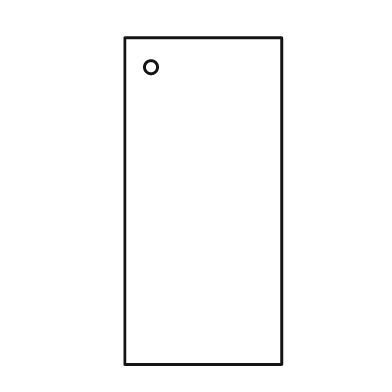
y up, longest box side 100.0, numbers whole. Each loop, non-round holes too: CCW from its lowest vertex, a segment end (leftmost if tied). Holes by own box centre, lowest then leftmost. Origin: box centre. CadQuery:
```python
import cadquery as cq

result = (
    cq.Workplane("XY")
    .moveTo(-24.0, -50.0)
    .lineTo(24.0, -50.0)
    .lineTo(24.0, 50.0)
    .lineTo(-24.0, 50.0)
    .close()
    .moveTo(-16.0, 41.0)
    .circle(2.0)
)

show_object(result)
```